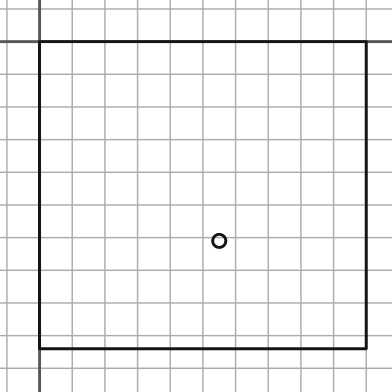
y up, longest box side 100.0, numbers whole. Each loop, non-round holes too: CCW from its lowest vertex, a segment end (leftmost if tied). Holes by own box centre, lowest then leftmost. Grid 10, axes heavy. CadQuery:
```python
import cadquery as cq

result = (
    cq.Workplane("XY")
    .moveTo(0.0, -94.0)
    .lineTo(100.0, -94.0)
    .lineTo(100.0, 0.0)
    .lineTo(0.0, 0.0)
    .close()
    .moveTo(55.0, -61.0)
    .circle(2.0)
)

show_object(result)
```